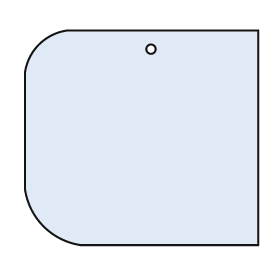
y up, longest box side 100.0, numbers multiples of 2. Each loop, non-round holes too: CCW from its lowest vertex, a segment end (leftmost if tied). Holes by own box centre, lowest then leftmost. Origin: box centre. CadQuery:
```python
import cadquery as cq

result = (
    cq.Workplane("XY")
    .moveTo(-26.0, -46.0)
    .lineTo(50.0, -46.0)
    .lineTo(50.0, 46.0)
    .lineTo(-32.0, 46.0)
    .threePointArc((-44.0, 40.0), (-50.0, 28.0))
    .lineTo(-50.0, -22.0)
    .threePointArc((-42.0, -38.0), (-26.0, -46.0))
    .close()
    .moveTo(4.0, 38.0)
    .circle(2.0)
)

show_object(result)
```